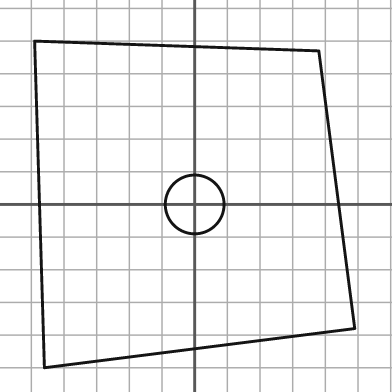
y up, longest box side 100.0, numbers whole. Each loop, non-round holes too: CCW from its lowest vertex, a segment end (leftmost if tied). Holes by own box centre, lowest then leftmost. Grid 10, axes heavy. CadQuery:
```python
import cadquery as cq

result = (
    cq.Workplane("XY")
    .moveTo(-46.0, -50.0)
    .lineTo(49.0, -38.0)
    .lineTo(38.0, 47.0)
    .lineTo(-49.0, 50.0)
    .close()
    .moveTo(0.0, 0.0)
    .circle(9.0)
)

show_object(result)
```